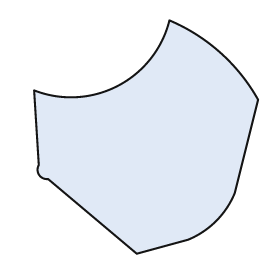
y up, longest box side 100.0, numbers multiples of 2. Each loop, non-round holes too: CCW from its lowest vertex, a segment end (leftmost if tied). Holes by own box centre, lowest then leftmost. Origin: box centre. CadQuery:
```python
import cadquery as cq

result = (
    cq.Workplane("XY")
    .moveTo(-4.0, -50.0)
    .lineTo(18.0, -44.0)
    .threePointArc((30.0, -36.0), (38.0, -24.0))
    .lineTo(48.0, 16.0)
    .threePointArc((32.0, 36.0), (10.0, 50.0))
    .threePointArc((-12.0, 22.0), (-48.0, 20.0))
    .lineTo(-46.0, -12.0)
    .threePointArc((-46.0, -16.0), (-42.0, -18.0))
    .close()
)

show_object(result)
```